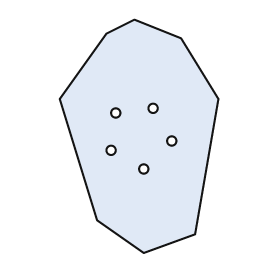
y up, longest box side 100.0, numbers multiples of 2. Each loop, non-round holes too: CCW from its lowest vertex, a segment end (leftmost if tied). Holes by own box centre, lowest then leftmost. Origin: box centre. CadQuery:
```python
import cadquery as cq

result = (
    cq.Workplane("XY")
    .moveTo(2.0, -50.0)
    .lineTo(24.0, -42.0)
    .lineTo(34.0, 16.0)
    .lineTo(18.0, 42.0)
    .lineTo(-2.0, 50.0)
    .lineTo(-14.0, 44.0)
    .lineTo(-34.0, 16.0)
    .lineTo(-18.0, -36.0)
    .close()
    .moveTo(2.0, -14.0)
    .circle(2.0)
    .moveTo(-12.0, -6.0)
    .circle(2.0)
    .moveTo(14.0, -2.0)
    .circle(2.0)
    .moveTo(-10.0, 10.0)
    .circle(2.0)
    .moveTo(6.0, 12.0)
    .circle(2.0)
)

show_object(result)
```